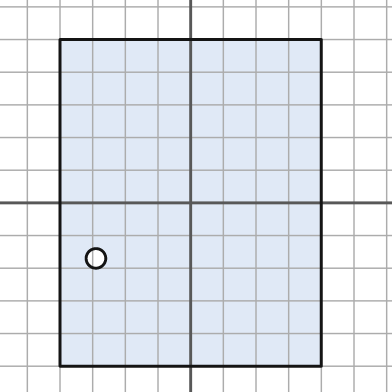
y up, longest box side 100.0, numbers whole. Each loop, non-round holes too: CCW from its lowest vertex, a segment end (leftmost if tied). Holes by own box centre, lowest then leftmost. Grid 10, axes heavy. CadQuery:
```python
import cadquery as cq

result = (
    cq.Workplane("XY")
    .moveTo(-40.0, -50.0)
    .lineTo(40.0, -50.0)
    .lineTo(40.0, 50.0)
    .lineTo(-40.0, 50.0)
    .close()
    .moveTo(-29.0, -17.0)
    .circle(3.0)
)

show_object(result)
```